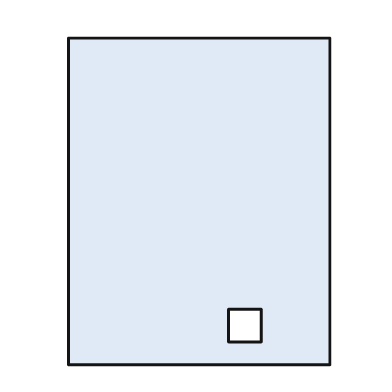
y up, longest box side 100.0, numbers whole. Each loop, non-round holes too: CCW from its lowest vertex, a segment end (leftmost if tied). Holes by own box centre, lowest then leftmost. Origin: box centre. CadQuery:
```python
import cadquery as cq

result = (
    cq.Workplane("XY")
    .moveTo(-40.0, -50.0)
    .lineTo(40.0, -50.0)
    .lineTo(40.0, 50.0)
    .lineTo(-40.0, 50.0)
    .close()
    .moveTo(9.0, -43.0)
    .lineTo(19.0, -43.0)
    .lineTo(19.0, -33.0)
    .lineTo(9.0, -33.0)
    .close()
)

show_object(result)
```